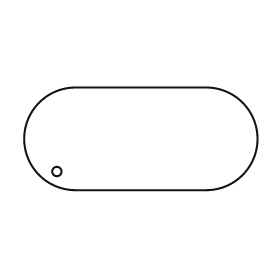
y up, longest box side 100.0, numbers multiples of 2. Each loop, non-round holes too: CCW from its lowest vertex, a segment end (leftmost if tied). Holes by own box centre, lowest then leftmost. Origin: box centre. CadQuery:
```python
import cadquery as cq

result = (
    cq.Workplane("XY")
    .moveTo(-28.0, -22.0)
    .lineTo(28.0, -22.0)
    .threePointArc((50.0, 0.0), (28.0, 22.0))
    .lineTo(-28.0, 22.0)
    .threePointArc((-50.0, 0.0), (-28.0, -22.0))
    .close()
    .moveTo(-36.0, -14.0)
    .circle(2.0)
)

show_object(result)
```